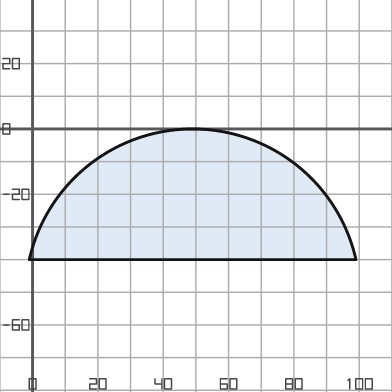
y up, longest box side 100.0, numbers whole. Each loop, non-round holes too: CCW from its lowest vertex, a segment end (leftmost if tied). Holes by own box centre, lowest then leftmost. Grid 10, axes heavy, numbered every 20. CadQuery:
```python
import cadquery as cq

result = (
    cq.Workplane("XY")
    .moveTo(-1.0, -40.0)
    .lineTo(99.0, -40.0)
    .threePointArc((49.0, 0.0), (-1.0, -40.0))
    .close()
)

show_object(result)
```